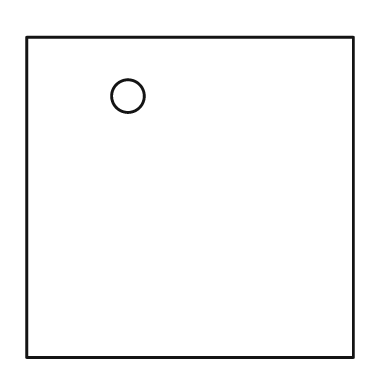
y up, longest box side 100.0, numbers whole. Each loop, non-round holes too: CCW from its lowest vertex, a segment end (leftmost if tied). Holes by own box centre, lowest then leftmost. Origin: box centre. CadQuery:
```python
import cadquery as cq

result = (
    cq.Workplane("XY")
    .moveTo(-50.0, -49.0)
    .lineTo(50.0, -49.0)
    .lineTo(50.0, 49.0)
    .lineTo(-50.0, 49.0)
    .close()
    .moveTo(-19.0, 31.0)
    .circle(5.0)
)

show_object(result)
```